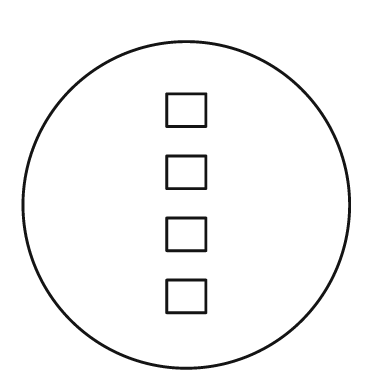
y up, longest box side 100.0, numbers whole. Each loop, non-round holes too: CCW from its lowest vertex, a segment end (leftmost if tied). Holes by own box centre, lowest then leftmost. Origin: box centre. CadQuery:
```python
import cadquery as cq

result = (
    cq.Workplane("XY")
    .moveTo(0.0, 0.0)
    .circle(50.0)
    .moveTo(-6.0, -33.0)
    .lineTo(6.0, -33.0)
    .lineTo(6.0, -23.0)
    .lineTo(-6.0, -23.0)
    .close()
    .moveTo(-6.0, -14.0)
    .lineTo(6.0, -14.0)
    .lineTo(6.0, -4.0)
    .lineTo(-6.0, -4.0)
    .close()
    .moveTo(-6.0, 5.0)
    .lineTo(6.0, 5.0)
    .lineTo(6.0, 15.0)
    .lineTo(-6.0, 15.0)
    .close()
    .moveTo(-6.0, 24.0)
    .lineTo(6.0, 24.0)
    .lineTo(6.0, 34.0)
    .lineTo(-6.0, 34.0)
    .close()
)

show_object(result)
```